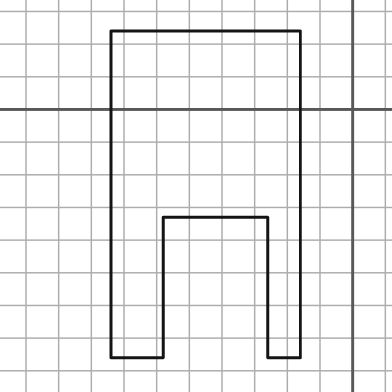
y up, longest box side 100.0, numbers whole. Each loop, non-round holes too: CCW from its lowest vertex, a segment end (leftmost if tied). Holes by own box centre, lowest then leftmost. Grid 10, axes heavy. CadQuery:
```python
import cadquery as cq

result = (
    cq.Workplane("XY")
    .moveTo(-74.0, -76.0)
    .lineTo(-58.0, -76.0)
    .lineTo(-58.0, -33.0)
    .lineTo(-26.0, -33.0)
    .lineTo(-26.0, -76.0)
    .lineTo(-16.0, -76.0)
    .lineTo(-16.0, 24.0)
    .lineTo(-74.0, 24.0)
    .close()
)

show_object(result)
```